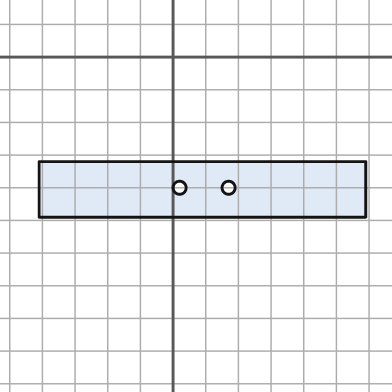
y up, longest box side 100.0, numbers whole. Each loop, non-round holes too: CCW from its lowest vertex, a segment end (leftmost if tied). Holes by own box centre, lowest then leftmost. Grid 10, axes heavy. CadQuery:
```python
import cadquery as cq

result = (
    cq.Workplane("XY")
    .moveTo(-41.0, -49.0)
    .lineTo(59.0, -49.0)
    .lineTo(59.0, -32.0)
    .lineTo(-41.0, -32.0)
    .close()
    .moveTo(2.0, -40.0)
    .circle(2.0)
    .moveTo(17.0, -40.0)
    .circle(2.0)
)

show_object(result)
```